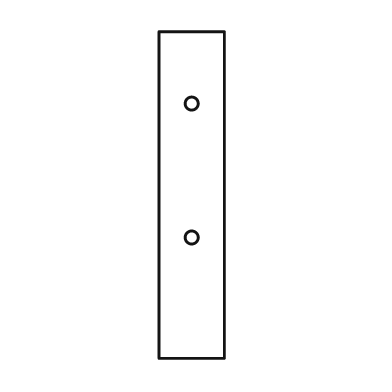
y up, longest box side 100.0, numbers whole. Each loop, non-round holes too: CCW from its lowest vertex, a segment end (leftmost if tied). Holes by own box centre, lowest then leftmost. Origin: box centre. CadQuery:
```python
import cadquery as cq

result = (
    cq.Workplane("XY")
    .moveTo(-10.0, -50.0)
    .lineTo(10.0, -50.0)
    .lineTo(10.0, 50.0)
    .lineTo(-10.0, 50.0)
    .close()
    .moveTo(0.0, -13.0)
    .circle(2.0)
    .moveTo(0.0, 28.0)
    .circle(2.0)
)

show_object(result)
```